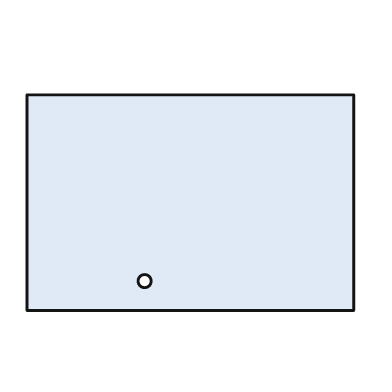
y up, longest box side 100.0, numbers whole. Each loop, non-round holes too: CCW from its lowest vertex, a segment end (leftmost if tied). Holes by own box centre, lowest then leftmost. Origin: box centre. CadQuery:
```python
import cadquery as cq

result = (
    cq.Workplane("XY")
    .moveTo(-50.0, -33.0)
    .lineTo(50.0, -33.0)
    .lineTo(50.0, 33.0)
    .lineTo(-50.0, 33.0)
    .close()
    .moveTo(-14.0, -24.0)
    .circle(2.0)
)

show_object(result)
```